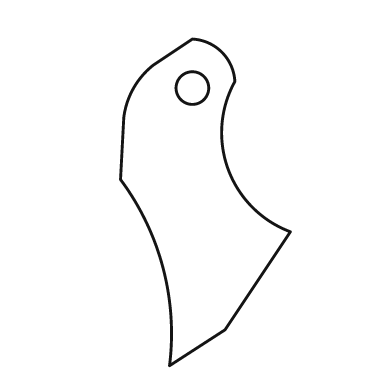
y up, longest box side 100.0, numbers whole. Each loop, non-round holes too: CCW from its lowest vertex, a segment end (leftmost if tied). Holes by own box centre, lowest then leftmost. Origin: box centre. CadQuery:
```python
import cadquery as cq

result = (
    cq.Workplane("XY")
    .moveTo(-11.0, -50.0)
    .lineTo(6.0, -39.0)
    .lineTo(26.0, -9.0)
    .threePointArc((7.0, 10.0), (9.0, 37.0))
    .threePointArc((5.0, 46.0), (-4.0, 50.0))
    .lineTo(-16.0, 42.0)
    .threePointArc((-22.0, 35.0), (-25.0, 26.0))
    .lineTo(-26.0, 7.0)
    .threePointArc((-13.0, -20.0), (-11.0, -50.0))
    .close()
    .moveTo(-4.0, 35.0)
    .circle(5.0)
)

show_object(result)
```